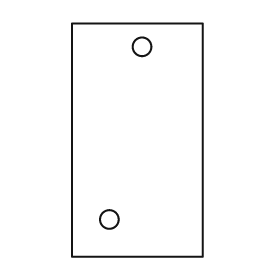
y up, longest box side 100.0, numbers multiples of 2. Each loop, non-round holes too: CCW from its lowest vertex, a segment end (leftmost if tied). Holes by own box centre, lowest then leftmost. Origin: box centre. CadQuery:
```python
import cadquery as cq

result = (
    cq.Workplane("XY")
    .moveTo(-28.0, -50.0)
    .lineTo(28.0, -50.0)
    .lineTo(28.0, 50.0)
    .lineTo(-28.0, 50.0)
    .close()
    .moveTo(-12.0, -34.0)
    .circle(4.0)
    .moveTo(2.0, 40.0)
    .circle(4.0)
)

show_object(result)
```